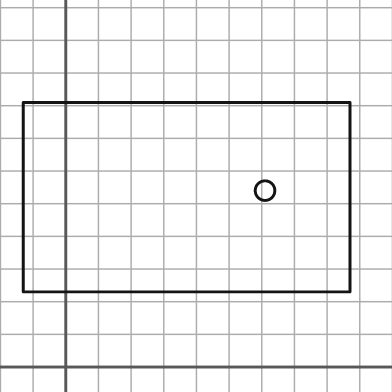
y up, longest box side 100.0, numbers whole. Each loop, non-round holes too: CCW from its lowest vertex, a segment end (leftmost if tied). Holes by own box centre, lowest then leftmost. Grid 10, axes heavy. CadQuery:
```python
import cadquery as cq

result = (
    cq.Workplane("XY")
    .moveTo(-13.0, 23.0)
    .lineTo(87.0, 23.0)
    .lineTo(87.0, 81.0)
    .lineTo(-13.0, 81.0)
    .close()
    .moveTo(61.0, 54.0)
    .circle(3.0)
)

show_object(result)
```